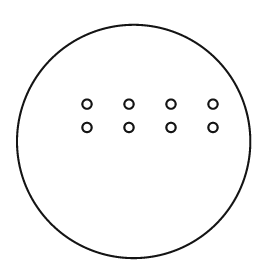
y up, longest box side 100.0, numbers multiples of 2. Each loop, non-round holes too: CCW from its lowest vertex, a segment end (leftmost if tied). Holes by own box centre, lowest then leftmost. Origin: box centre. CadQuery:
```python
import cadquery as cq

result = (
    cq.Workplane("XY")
    .moveTo(0.0, 0.0)
    .circle(50.0)
    .moveTo(-20.0, 6.0)
    .circle(2.0)
    .moveTo(-2.0, 6.0)
    .circle(2.0)
    .moveTo(16.0, 6.0)
    .circle(2.0)
    .moveTo(34.0, 6.0)
    .circle(2.0)
    .moveTo(-20.0, 16.0)
    .circle(2.0)
    .moveTo(-2.0, 16.0)
    .circle(2.0)
    .moveTo(16.0, 16.0)
    .circle(2.0)
    .moveTo(34.0, 16.0)
    .circle(2.0)
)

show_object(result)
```